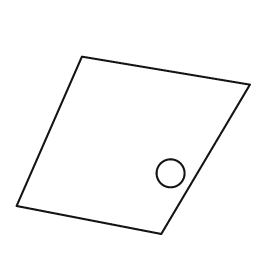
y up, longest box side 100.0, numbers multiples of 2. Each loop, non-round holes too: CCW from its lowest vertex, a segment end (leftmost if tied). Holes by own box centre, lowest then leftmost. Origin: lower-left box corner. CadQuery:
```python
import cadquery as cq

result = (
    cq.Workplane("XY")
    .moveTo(62.0, 0.0)
    .lineTo(100.0, 64.0)
    .lineTo(28.0, 76.0)
    .lineTo(0.0, 12.0)
    .close()
    .moveTo(66.0, 26.0)
    .circle(6.0)
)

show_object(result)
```